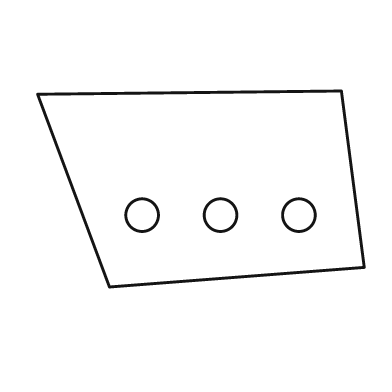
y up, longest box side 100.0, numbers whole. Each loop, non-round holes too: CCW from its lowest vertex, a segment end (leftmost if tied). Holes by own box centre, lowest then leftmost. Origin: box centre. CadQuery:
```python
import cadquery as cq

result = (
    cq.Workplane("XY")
    .moveTo(-28.0, -30.0)
    .lineTo(50.0, -24.0)
    .lineTo(43.0, 30.0)
    .lineTo(-50.0, 29.0)
    .close()
    .moveTo(-18.0, -8.0)
    .circle(5.0)
    .moveTo(6.0, -8.0)
    .circle(5.0)
    .moveTo(30.0, -8.0)
    .circle(5.0)
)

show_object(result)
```